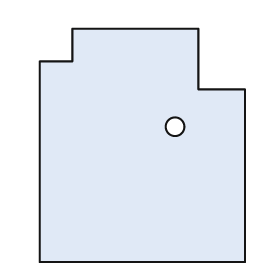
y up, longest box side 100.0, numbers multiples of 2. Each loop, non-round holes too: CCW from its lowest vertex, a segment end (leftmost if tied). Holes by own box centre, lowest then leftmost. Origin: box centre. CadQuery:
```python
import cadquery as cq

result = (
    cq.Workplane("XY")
    .moveTo(-44.0, -50.0)
    .lineTo(44.0, -50.0)
    .lineTo(44.0, 24.0)
    .lineTo(24.0, 24.0)
    .lineTo(24.0, 50.0)
    .lineTo(-30.0, 50.0)
    .lineTo(-30.0, 36.0)
    .lineTo(-44.0, 36.0)
    .close()
    .moveTo(14.0, 8.0)
    .circle(4.0)
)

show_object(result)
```